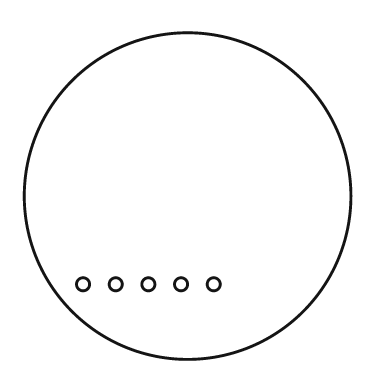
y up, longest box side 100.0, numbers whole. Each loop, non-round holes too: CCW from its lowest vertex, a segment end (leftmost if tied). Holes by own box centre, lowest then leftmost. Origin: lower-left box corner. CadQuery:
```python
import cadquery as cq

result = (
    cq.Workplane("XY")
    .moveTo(50.0, 50.0)
    .circle(50.0)
    .moveTo(18.0, 23.0)
    .circle(2.0)
    .moveTo(28.0, 23.0)
    .circle(2.0)
    .moveTo(38.0, 23.0)
    .circle(2.0)
    .moveTo(48.0, 23.0)
    .circle(2.0)
    .moveTo(58.0, 23.0)
    .circle(2.0)
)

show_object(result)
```